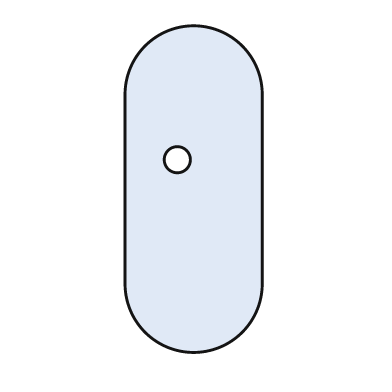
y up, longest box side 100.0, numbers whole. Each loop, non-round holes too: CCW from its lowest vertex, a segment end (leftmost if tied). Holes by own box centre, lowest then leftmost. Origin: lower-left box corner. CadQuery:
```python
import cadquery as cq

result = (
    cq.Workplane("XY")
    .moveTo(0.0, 21.0)
    .threePointArc((21.0, 0.0), (42.0, 21.0))
    .lineTo(42.0, 79.0)
    .threePointArc((21.0, 100.0), (0.0, 79.0))
    .close()
    .moveTo(16.0, 59.0)
    .circle(4.0)
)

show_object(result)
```